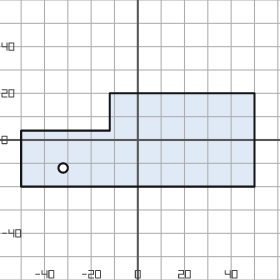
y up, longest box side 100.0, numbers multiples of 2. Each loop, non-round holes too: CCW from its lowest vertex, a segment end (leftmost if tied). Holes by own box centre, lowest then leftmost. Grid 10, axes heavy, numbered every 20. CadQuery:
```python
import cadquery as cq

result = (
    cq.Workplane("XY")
    .moveTo(-50.0, -20.0)
    .lineTo(50.0, -20.0)
    .lineTo(50.0, 20.0)
    .lineTo(-12.0, 20.0)
    .lineTo(-12.0, 4.0)
    .lineTo(-50.0, 4.0)
    .close()
    .moveTo(-32.0, -12.0)
    .circle(2.0)
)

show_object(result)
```